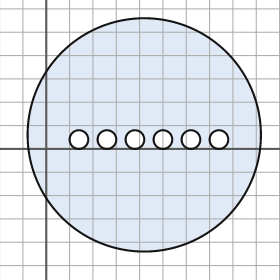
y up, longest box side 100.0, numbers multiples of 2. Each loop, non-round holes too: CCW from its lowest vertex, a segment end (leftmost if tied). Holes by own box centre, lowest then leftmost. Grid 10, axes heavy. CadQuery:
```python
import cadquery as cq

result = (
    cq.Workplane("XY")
    .moveTo(42.0, 6.0)
    .circle(50.0)
    .moveTo(14.0, 4.0)
    .circle(4.0)
    .moveTo(26.0, 4.0)
    .circle(4.0)
    .moveTo(38.0, 4.0)
    .circle(4.0)
    .moveTo(50.0, 4.0)
    .circle(4.0)
    .moveTo(62.0, 4.0)
    .circle(4.0)
    .moveTo(74.0, 4.0)
    .circle(4.0)
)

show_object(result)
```